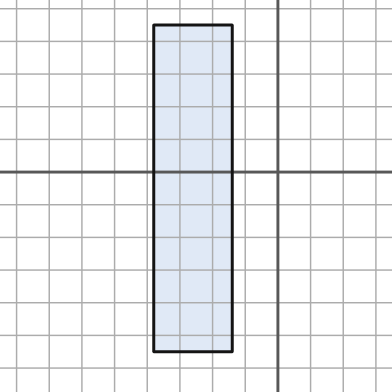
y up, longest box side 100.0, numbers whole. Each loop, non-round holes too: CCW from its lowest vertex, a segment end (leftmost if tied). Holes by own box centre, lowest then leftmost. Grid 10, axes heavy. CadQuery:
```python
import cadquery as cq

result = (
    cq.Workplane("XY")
    .moveTo(-38.0, -55.0)
    .lineTo(-14.0, -55.0)
    .lineTo(-14.0, 45.0)
    .lineTo(-38.0, 45.0)
    .close()
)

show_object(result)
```